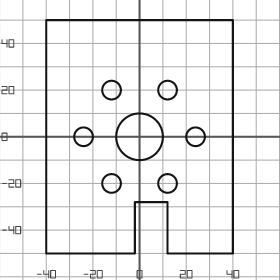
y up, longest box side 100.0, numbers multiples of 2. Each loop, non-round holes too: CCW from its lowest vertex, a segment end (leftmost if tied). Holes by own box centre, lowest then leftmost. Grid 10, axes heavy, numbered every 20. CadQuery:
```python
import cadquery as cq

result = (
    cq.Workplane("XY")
    .moveTo(-40.0, -50.0)
    .lineTo(-2.0, -50.0)
    .lineTo(-2.0, -28.0)
    .lineTo(12.0, -28.0)
    .lineTo(12.0, -50.0)
    .lineTo(40.0, -50.0)
    .lineTo(40.0, 50.0)
    .lineTo(-40.0, 50.0)
    .close()
    .moveTo(-12.0, -20.0)
    .circle(4.0)
    .moveTo(12.0, -20.0)
    .circle(4.0)
    .moveTo(-24.0, 0.0)
    .circle(4.0)
    .moveTo(0.0, 0.0)
    .circle(10.0)
    .moveTo(24.0, 0.0)
    .circle(4.0)
    .moveTo(-12.0, 20.0)
    .circle(4.0)
    .moveTo(12.0, 20.0)
    .circle(4.0)
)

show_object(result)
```